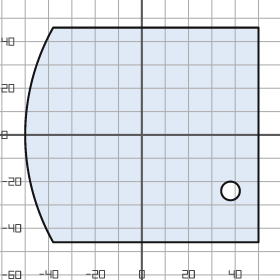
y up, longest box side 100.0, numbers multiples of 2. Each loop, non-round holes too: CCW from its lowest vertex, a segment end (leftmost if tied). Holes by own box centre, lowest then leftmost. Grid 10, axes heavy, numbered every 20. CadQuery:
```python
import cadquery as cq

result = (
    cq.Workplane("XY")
    .moveTo(-38.0, -46.0)
    .lineTo(50.0, -46.0)
    .lineTo(50.0, 46.0)
    .lineTo(-38.0, 46.0)
    .threePointArc((-50.0, 0.0), (-38.0, -46.0))
    .close()
    .moveTo(38.0, -24.0)
    .circle(4.0)
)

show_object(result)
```